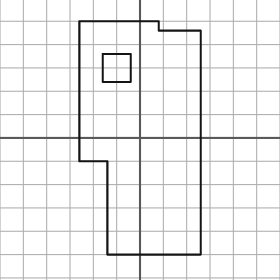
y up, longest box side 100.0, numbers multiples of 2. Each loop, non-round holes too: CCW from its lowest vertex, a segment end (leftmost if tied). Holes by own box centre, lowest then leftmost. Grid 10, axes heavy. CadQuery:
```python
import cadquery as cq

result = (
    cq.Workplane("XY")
    .moveTo(-14.0, -50.0)
    .lineTo(26.0, -50.0)
    .lineTo(26.0, 46.0)
    .lineTo(8.0, 46.0)
    .lineTo(8.0, 50.0)
    .lineTo(-26.0, 50.0)
    .lineTo(-26.0, -10.0)
    .lineTo(-14.0, -10.0)
    .close()
    .moveTo(-16.0, 24.0)
    .lineTo(-4.0, 24.0)
    .lineTo(-4.0, 36.0)
    .lineTo(-16.0, 36.0)
    .close()
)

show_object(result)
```